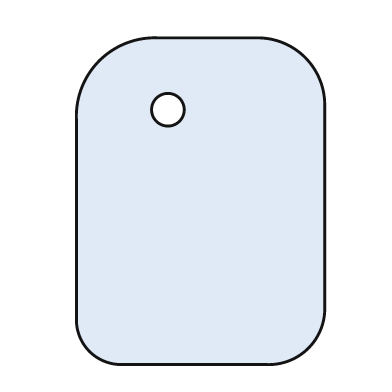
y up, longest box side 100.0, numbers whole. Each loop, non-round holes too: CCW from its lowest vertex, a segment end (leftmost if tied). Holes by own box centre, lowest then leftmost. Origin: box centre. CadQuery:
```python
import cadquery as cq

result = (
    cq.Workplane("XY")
    .moveTo(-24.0, -50.0)
    .lineTo(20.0, -50.0)
    .threePointArc((33.0, -45.0), (38.0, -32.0))
    .lineTo(38.0, 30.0)
    .threePointArc((32.0, 44.0), (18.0, 50.0))
    .lineTo(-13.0, 50.0)
    .threePointArc((-31.0, 43.0), (-38.0, 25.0))
    .lineTo(-38.0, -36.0)
    .threePointArc((-34.0, -46.0), (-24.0, -50.0))
    .close()
    .moveTo(-10.0, 28.0)
    .circle(5.0)
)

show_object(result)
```